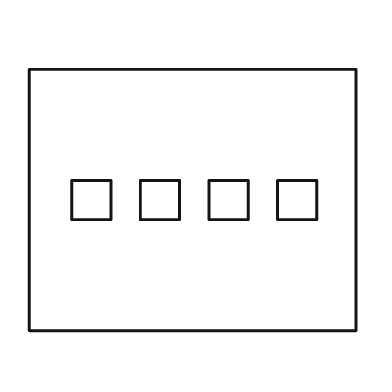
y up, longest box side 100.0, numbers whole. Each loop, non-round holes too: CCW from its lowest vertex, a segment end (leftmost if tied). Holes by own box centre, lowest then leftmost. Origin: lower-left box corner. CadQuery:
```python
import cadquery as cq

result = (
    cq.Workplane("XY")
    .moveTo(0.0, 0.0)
    .lineTo(100.0, 0.0)
    .lineTo(100.0, 80.0)
    .lineTo(0.0, 80.0)
    .close()
    .moveTo(13.0, 34.0)
    .lineTo(25.0, 34.0)
    .lineTo(25.0, 46.0)
    .lineTo(13.0, 46.0)
    .close()
    .moveTo(34.0, 34.0)
    .lineTo(46.0, 34.0)
    .lineTo(46.0, 46.0)
    .lineTo(34.0, 46.0)
    .close()
    .moveTo(55.0, 34.0)
    .lineTo(67.0, 34.0)
    .lineTo(67.0, 46.0)
    .lineTo(55.0, 46.0)
    .close()
    .moveTo(76.0, 34.0)
    .lineTo(88.0, 34.0)
    .lineTo(88.0, 46.0)
    .lineTo(76.0, 46.0)
    .close()
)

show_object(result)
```